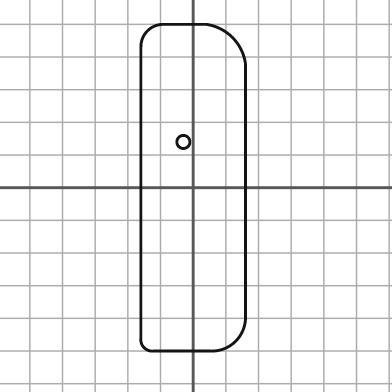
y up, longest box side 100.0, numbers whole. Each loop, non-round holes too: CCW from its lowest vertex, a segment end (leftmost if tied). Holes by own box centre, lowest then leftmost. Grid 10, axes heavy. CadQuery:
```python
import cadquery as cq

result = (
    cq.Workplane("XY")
    .moveTo(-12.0, -50.0)
    .lineTo(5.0, -50.0)
    .threePointArc((13.0, -47.0), (16.0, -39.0))
    .lineTo(16.0, 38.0)
    .threePointArc((12.0, 46.0), (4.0, 50.0))
    .lineTo(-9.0, 50.0)
    .threePointArc((-14.0, 48.0), (-16.0, 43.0))
    .lineTo(-16.0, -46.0)
    .threePointArc((-15.0, -49.0), (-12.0, -50.0))
    .close()
    .moveTo(-3.0, 14.0)
    .circle(2.0)
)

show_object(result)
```